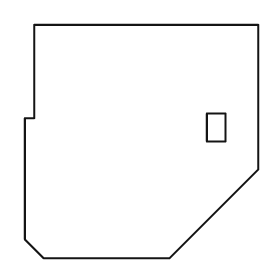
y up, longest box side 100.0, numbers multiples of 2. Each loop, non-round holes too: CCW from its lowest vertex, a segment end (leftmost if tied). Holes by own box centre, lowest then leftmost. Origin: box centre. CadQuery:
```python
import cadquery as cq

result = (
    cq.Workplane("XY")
    .moveTo(-42.0, -50.0)
    .lineTo(12.0, -50.0)
    .lineTo(50.0, -12.0)
    .lineTo(50.0, 50.0)
    .lineTo(-46.0, 50.0)
    .lineTo(-46.0, 10.0)
    .lineTo(-50.0, 10.0)
    .lineTo(-50.0, -42.0)
    .close()
    .moveTo(28.0, 0.0)
    .lineTo(36.0, 0.0)
    .lineTo(36.0, 12.0)
    .lineTo(28.0, 12.0)
    .close()
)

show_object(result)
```